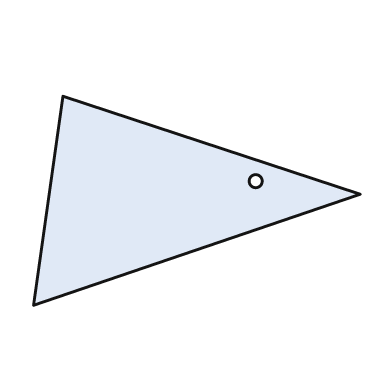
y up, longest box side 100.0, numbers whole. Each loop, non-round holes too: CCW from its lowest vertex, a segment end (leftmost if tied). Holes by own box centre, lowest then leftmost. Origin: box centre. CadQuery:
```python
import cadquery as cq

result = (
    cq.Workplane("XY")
    .moveTo(-50.0, -32.0)
    .lineTo(50.0, 2.0)
    .lineTo(-41.0, 32.0)
    .close()
    .moveTo(18.0, 6.0)
    .circle(2.0)
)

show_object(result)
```